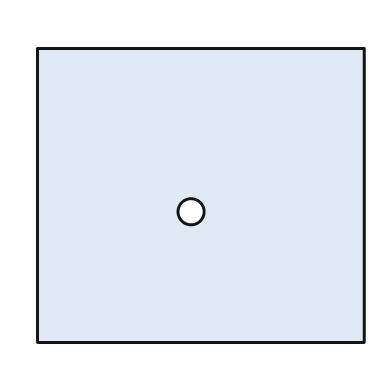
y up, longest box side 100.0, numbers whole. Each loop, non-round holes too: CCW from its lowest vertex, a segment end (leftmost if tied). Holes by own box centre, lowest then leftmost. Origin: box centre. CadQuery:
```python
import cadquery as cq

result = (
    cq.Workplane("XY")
    .moveTo(-50.0, -45.0)
    .lineTo(50.0, -45.0)
    .lineTo(50.0, 45.0)
    .lineTo(-50.0, 45.0)
    .close()
    .moveTo(-3.0, -5.0)
    .circle(4.0)
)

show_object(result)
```